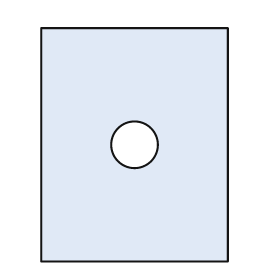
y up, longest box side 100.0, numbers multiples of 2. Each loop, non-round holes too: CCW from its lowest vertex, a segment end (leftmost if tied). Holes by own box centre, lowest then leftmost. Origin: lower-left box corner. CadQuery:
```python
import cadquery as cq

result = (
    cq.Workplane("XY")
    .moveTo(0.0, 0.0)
    .lineTo(80.0, 0.0)
    .lineTo(80.0, 100.0)
    .lineTo(0.0, 100.0)
    .close()
    .moveTo(40.0, 50.0)
    .circle(10.0)
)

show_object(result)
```